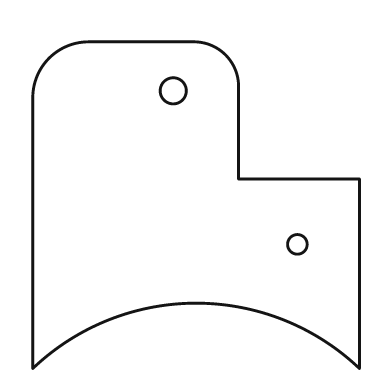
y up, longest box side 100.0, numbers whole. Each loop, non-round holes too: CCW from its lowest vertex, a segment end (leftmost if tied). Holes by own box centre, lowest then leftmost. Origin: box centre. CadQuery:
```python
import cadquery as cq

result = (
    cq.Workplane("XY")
    .moveTo(-50.0, -50.0)
    .threePointArc((0.0, -30.0), (50.0, -50.0))
    .lineTo(50.0, 8.0)
    .lineTo(13.0, 8.0)
    .lineTo(13.0, 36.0)
    .threePointArc((9.0, 46.0), (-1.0, 50.0))
    .lineTo(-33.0, 50.0)
    .threePointArc((-45.0, 45.0), (-50.0, 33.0))
    .close()
    .moveTo(31.0, -12.0)
    .circle(3.0)
    .moveTo(-7.0, 35.0)
    .circle(4.0)
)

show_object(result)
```